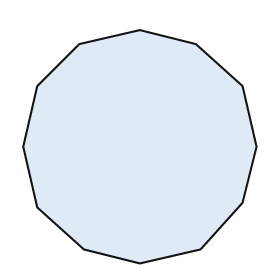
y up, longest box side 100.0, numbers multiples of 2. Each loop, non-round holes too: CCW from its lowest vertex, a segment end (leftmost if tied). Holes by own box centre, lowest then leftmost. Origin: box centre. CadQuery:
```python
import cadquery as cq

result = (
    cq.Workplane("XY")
    .moveTo(0.0, -50.0)
    .lineTo(26.0, -44.0)
    .lineTo(44.0, -24.0)
    .lineTo(50.0, 0.0)
    .lineTo(44.0, 26.0)
    .lineTo(24.0, 44.0)
    .lineTo(0.0, 50.0)
    .lineTo(-26.0, 44.0)
    .lineTo(-44.0, 26.0)
    .lineTo(-50.0, 0.0)
    .lineTo(-44.0, -26.0)
    .lineTo(-24.0, -44.0)
    .close()
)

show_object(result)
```